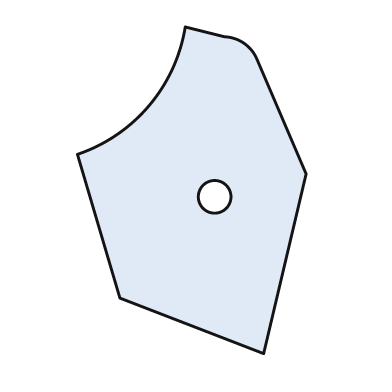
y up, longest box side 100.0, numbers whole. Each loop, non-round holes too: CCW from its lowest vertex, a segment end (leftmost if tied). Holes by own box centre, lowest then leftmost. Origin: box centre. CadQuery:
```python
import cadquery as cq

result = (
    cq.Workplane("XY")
    .moveTo(22.0, -50.0)
    .lineTo(35.0, 5.0)
    .lineTo(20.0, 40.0)
    .threePointArc((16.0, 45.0), (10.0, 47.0))
    .lineTo(-2.0, 50.0)
    .threePointArc((-13.0, 26.0), (-35.0, 11.0))
    .lineTo(-22.0, -33.0)
    .close()
    .moveTo(7.0, -2.0)
    .circle(5.0)
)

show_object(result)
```